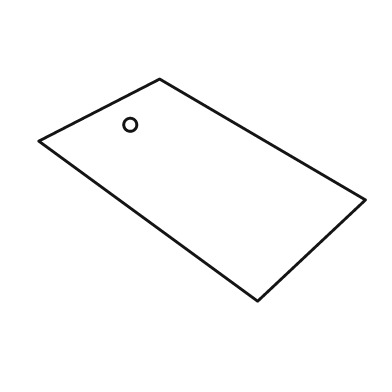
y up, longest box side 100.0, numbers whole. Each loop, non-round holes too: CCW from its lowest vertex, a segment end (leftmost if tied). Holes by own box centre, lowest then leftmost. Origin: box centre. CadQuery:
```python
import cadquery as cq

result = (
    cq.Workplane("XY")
    .moveTo(17.0, -34.0)
    .lineTo(50.0, -3.0)
    .lineTo(-13.0, 34.0)
    .lineTo(-50.0, 15.0)
    .close()
    .moveTo(-22.0, 20.0)
    .circle(2.0)
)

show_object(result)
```